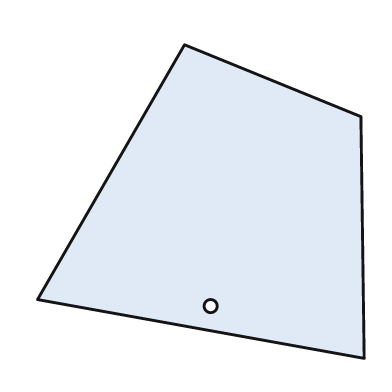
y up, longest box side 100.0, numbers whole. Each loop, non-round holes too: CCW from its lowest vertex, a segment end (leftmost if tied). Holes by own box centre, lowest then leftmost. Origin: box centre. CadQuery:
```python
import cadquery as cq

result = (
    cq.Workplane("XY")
    .moveTo(50.0, -48.0)
    .lineTo(49.0, 26.0)
    .lineTo(-5.0, 48.0)
    .lineTo(-50.0, -30.0)
    .close()
    .moveTo(3.0, -32.0)
    .circle(2.0)
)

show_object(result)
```